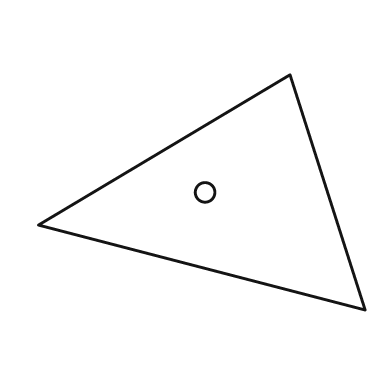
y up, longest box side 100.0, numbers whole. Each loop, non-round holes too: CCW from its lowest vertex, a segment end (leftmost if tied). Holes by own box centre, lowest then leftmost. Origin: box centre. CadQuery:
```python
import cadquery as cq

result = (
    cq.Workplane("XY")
    .moveTo(50.0, -36.0)
    .lineTo(27.0, 36.0)
    .lineTo(-50.0, -10.0)
    .close()
    .moveTo(1.0, 0.0)
    .circle(3.0)
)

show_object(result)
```